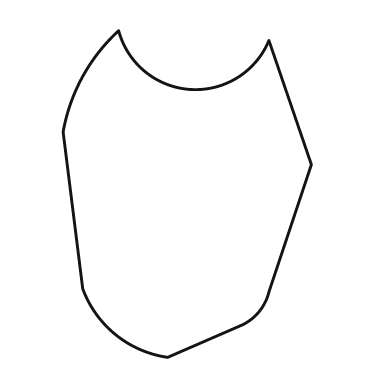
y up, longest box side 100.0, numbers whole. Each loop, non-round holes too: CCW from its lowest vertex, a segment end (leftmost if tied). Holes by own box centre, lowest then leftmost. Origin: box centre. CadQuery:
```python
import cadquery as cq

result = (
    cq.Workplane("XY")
    .moveTo(-6.0, -50.0)
    .lineTo(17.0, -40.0)
    .threePointArc((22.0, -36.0), (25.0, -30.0))
    .lineTo(38.0, 9.0)
    .lineTo(25.0, 47.0)
    .threePointArc((1.0, 32.0), (-21.0, 50.0))
    .threePointArc((-32.0, 36.0), (-38.0, 19.0))
    .lineTo(-32.0, -29.0)
    .threePointArc((-22.0, -43.0), (-6.0, -50.0))
    .close()
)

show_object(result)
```